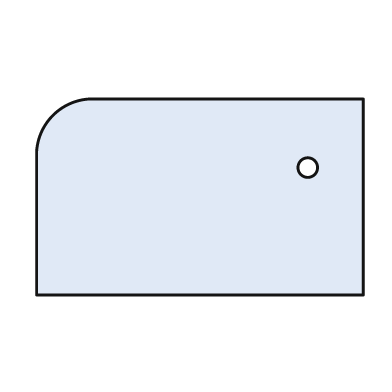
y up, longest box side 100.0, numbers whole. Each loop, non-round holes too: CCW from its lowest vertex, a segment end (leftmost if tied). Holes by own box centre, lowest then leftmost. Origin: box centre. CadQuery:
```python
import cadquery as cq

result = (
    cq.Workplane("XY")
    .moveTo(-50.0, -30.0)
    .lineTo(50.0, -30.0)
    .lineTo(50.0, 30.0)
    .lineTo(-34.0, 30.0)
    .threePointArc((-45.0, 25.0), (-50.0, 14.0))
    .close()
    .moveTo(33.0, 9.0)
    .circle(3.0)
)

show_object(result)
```